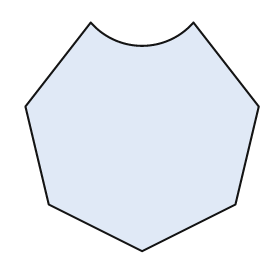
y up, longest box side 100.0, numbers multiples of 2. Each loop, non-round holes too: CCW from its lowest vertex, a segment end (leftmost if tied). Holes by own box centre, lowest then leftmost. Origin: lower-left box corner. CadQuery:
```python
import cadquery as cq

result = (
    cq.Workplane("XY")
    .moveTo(50.0, 0.0)
    .lineTo(90.0, 20.0)
    .lineTo(100.0, 62.0)
    .lineTo(72.0, 98.0)
    .threePointArc((50.0, 88.0), (28.0, 98.0))
    .lineTo(0.0, 62.0)
    .lineTo(10.0, 20.0)
    .close()
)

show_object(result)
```